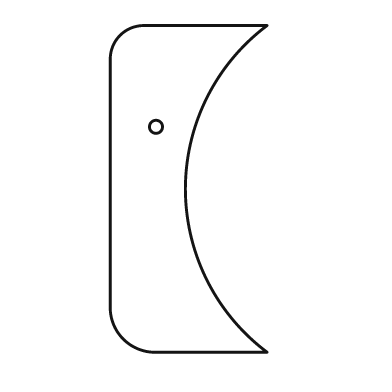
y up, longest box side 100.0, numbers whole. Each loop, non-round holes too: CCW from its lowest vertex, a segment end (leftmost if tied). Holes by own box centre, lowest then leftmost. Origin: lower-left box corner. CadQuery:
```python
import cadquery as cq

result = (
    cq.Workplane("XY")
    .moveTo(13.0, 0.0)
    .lineTo(48.0, 0.0)
    .threePointArc((23.0, 50.0), (48.0, 100.0))
    .lineTo(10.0, 100.0)
    .threePointArc((3.0, 97.0), (0.0, 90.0))
    .lineTo(0.0, 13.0)
    .threePointArc((4.0, 4.0), (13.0, 0.0))
    .close()
    .moveTo(14.0, 69.0)
    .circle(2.0)
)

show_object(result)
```